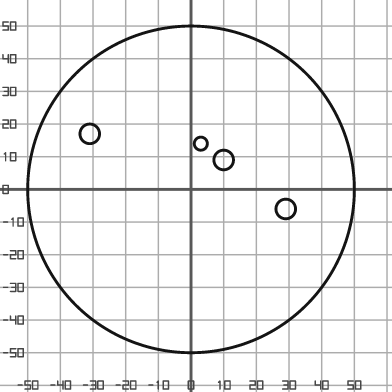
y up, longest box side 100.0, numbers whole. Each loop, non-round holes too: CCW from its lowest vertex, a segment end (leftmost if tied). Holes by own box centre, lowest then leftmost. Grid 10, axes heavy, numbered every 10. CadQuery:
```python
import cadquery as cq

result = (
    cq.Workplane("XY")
    .moveTo(0.0, 0.0)
    .circle(50.0)
    .moveTo(29.0, -6.0)
    .circle(3.0)
    .moveTo(10.0, 9.0)
    .circle(3.0)
    .moveTo(3.0, 14.0)
    .circle(2.0)
    .moveTo(-31.0, 17.0)
    .circle(3.0)
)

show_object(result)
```